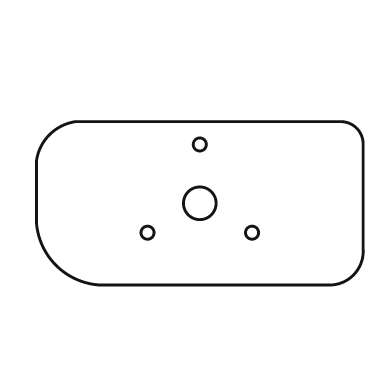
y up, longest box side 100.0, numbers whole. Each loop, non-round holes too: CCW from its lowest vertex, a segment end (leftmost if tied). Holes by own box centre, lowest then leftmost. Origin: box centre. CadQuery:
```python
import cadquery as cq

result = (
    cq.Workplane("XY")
    .moveTo(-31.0, -25.0)
    .lineTo(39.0, -25.0)
    .threePointArc((47.0, -22.0), (50.0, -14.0))
    .lineTo(50.0, 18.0)
    .threePointArc((48.0, 23.0), (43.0, 25.0))
    .lineTo(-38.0, 25.0)
    .threePointArc((-46.0, 21.0), (-50.0, 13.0))
    .lineTo(-50.0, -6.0)
    .threePointArc((-44.0, -19.0), (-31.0, -25.0))
    .close()
    .moveTo(-16.0, -9.0)
    .circle(2.0)
    .moveTo(16.0, -9.0)
    .circle(2.0)
    .moveTo(0.0, 0.0)
    .circle(5.0)
    .moveTo(0.0, 18.0)
    .circle(2.0)
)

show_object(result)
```